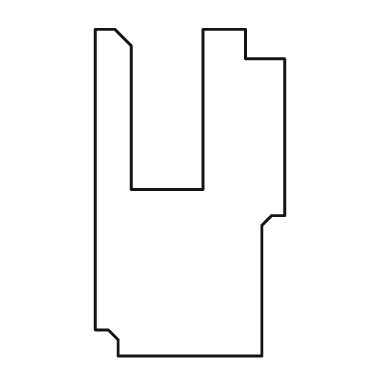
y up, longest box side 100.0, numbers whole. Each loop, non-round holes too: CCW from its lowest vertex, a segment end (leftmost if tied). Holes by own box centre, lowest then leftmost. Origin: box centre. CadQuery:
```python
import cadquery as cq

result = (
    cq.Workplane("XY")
    .moveTo(-22.0, -50.0)
    .lineTo(22.0, -50.0)
    .lineTo(22.0, -10.0)
    .lineTo(25.0, -7.0)
    .lineTo(29.0, -7.0)
    .lineTo(29.0, 41.0)
    .lineTo(17.0, 41.0)
    .lineTo(17.0, 50.0)
    .lineTo(4.0, 50.0)
    .lineTo(4.0, 1.0)
    .lineTo(-18.0, 1.0)
    .lineTo(-18.0, 45.0)
    .lineTo(-23.0, 50.0)
    .lineTo(-29.0, 50.0)
    .lineTo(-29.0, -42.0)
    .lineTo(-25.0, -42.0)
    .lineTo(-22.0, -45.0)
    .close()
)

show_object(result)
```